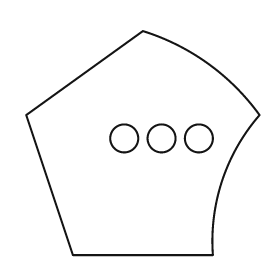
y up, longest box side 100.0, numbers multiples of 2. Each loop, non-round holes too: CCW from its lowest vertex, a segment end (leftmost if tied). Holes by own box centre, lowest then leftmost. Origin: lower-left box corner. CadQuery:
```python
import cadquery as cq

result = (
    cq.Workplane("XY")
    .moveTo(20.0, 0.0)
    .lineTo(80.0, 0.0)
    .threePointArc((84.0, 32.0), (100.0, 60.0))
    .threePointArc((78.0, 82.0), (50.0, 96.0))
    .lineTo(0.0, 60.0)
    .close()
    .moveTo(42.0, 50.0)
    .circle(6.0)
    .moveTo(58.0, 50.0)
    .circle(6.0)
    .moveTo(74.0, 50.0)
    .circle(6.0)
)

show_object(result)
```